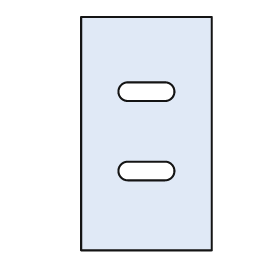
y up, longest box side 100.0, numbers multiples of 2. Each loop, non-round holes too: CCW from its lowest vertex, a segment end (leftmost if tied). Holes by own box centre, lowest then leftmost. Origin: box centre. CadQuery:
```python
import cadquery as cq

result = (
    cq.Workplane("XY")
    .moveTo(-28.0, -50.0)
    .lineTo(28.0, -50.0)
    .lineTo(28.0, 50.0)
    .lineTo(-28.0, 50.0)
    .close()
    .moveTo(-8.0, -20.0)
    .lineTo(8.0, -20.0)
    .threePointArc((12.0, -16.0), (8.0, -12.0))
    .lineTo(-8.0, -12.0)
    .threePointArc((-12.0, -16.0), (-8.0, -20.0))
    .close()
    .moveTo(-8.0, 14.0)
    .lineTo(8.0, 14.0)
    .threePointArc((12.0, 18.0), (8.0, 22.0))
    .lineTo(-8.0, 22.0)
    .threePointArc((-12.0, 18.0), (-8.0, 14.0))
    .close()
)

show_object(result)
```